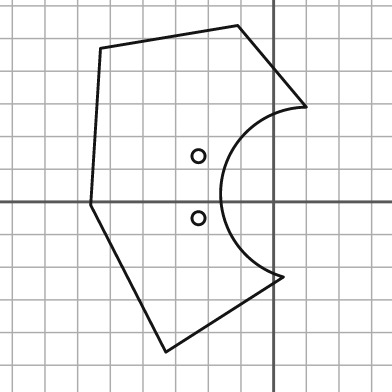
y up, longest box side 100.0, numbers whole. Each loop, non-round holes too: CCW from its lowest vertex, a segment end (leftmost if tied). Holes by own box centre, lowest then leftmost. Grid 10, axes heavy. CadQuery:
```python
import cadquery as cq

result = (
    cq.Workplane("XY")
    .moveTo(-33.0, -46.0)
    .lineTo(3.0, -23.0)
    .threePointArc((-16.0, 6.0), (10.0, 29.0))
    .lineTo(-11.0, 54.0)
    .lineTo(-53.0, 47.0)
    .lineTo(-56.0, -1.0)
    .close()
    .moveTo(-23.0, -5.0)
    .circle(2.0)
    .moveTo(-23.0, 14.0)
    .circle(2.0)
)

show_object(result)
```